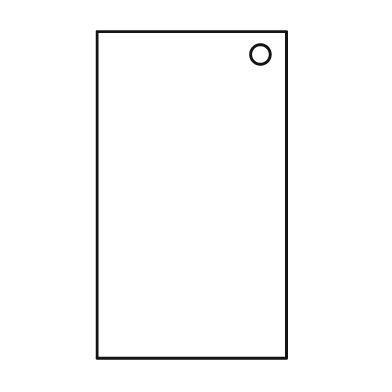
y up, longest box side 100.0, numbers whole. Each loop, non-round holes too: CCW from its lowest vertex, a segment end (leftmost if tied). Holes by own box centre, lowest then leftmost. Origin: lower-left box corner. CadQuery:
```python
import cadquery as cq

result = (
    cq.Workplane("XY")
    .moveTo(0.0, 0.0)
    .lineTo(58.0, 0.0)
    .lineTo(58.0, 100.0)
    .lineTo(0.0, 100.0)
    .close()
    .moveTo(50.0, 93.0)
    .circle(3.0)
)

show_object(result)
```